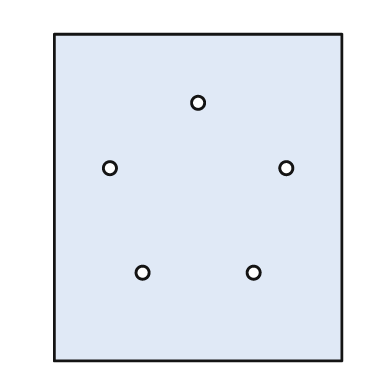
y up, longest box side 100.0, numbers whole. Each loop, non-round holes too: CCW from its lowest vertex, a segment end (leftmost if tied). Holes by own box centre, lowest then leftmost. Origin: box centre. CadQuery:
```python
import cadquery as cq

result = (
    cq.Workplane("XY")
    .moveTo(-44.0, -50.0)
    .lineTo(44.0, -50.0)
    .lineTo(44.0, 50.0)
    .lineTo(-44.0, 50.0)
    .close()
    .moveTo(-17.0, -23.0)
    .circle(2.0)
    .moveTo(17.0, -23.0)
    .circle(2.0)
    .moveTo(-27.0, 9.0)
    .circle(2.0)
    .moveTo(27.0, 9.0)
    .circle(2.0)
    .moveTo(0.0, 29.0)
    .circle(2.0)
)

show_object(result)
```